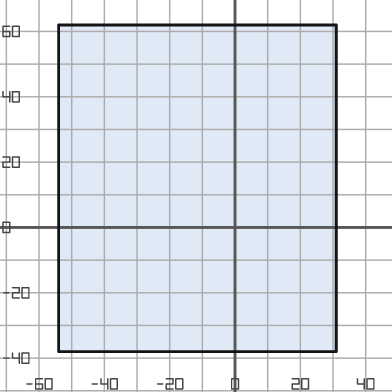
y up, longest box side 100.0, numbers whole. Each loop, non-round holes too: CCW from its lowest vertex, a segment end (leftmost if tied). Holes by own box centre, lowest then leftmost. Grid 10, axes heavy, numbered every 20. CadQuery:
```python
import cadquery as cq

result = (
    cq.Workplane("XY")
    .moveTo(-54.0, -38.0)
    .lineTo(31.0, -38.0)
    .lineTo(31.0, 62.0)
    .lineTo(-54.0, 62.0)
    .close()
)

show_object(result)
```